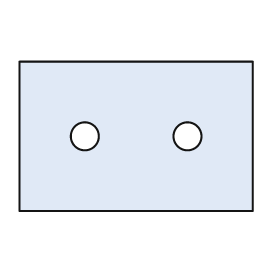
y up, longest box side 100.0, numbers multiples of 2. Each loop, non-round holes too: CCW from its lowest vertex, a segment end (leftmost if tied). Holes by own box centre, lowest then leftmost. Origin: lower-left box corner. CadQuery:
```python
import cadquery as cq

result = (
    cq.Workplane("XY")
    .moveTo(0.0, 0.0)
    .lineTo(100.0, 0.0)
    .lineTo(100.0, 64.0)
    .lineTo(0.0, 64.0)
    .close()
    .moveTo(28.0, 32.0)
    .circle(6.0)
    .moveTo(72.0, 32.0)
    .circle(6.0)
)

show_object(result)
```